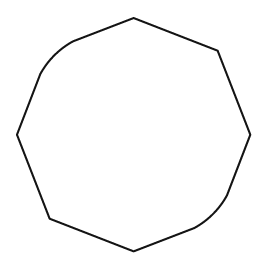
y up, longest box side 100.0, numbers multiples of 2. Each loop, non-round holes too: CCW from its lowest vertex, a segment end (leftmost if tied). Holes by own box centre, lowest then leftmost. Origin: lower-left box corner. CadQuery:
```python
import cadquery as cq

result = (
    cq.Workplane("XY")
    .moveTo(50.0, 0.0)
    .lineTo(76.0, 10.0)
    .threePointArc((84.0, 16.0), (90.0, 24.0))
    .lineTo(100.0, 50.0)
    .lineTo(86.0, 86.0)
    .lineTo(50.0, 100.0)
    .lineTo(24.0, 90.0)
    .threePointArc((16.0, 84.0), (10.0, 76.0))
    .lineTo(0.0, 50.0)
    .lineTo(14.0, 14.0)
    .close()
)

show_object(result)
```